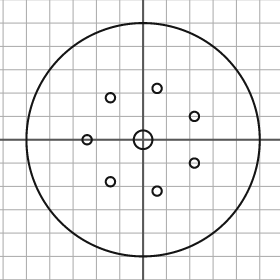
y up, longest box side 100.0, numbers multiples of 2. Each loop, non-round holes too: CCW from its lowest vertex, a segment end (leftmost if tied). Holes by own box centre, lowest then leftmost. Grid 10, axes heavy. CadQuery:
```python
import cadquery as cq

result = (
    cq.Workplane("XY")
    .moveTo(0.0, 0.0)
    .circle(50.0)
    .moveTo(6.0, -22.0)
    .circle(2.0)
    .moveTo(-14.0, -18.0)
    .circle(2.0)
    .moveTo(22.0, -10.0)
    .circle(2.0)
    .moveTo(-24.0, 0.0)
    .circle(2.0)
    .moveTo(0.0, 0.0)
    .circle(4.0)
    .moveTo(22.0, 10.0)
    .circle(2.0)
    .moveTo(-14.0, 18.0)
    .circle(2.0)
    .moveTo(6.0, 22.0)
    .circle(2.0)
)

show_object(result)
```